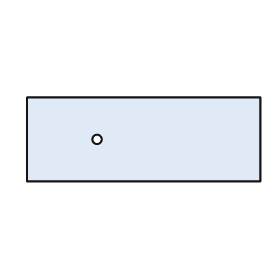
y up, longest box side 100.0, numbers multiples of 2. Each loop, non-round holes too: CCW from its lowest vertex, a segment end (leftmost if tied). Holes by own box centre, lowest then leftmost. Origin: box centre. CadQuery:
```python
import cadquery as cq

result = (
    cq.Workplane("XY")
    .moveTo(-50.0, -18.0)
    .lineTo(50.0, -18.0)
    .lineTo(50.0, 18.0)
    .lineTo(-50.0, 18.0)
    .close()
    .moveTo(-20.0, 0.0)
    .circle(2.0)
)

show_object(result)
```